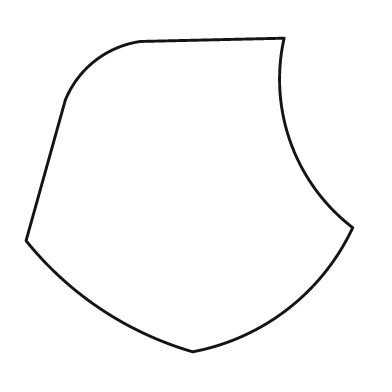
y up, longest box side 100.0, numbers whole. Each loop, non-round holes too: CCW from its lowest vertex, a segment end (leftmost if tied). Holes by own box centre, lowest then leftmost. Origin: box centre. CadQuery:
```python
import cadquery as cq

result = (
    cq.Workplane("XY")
    .moveTo(1.0, -48.0)
    .threePointArc((30.0, -35.0), (50.0, -10.0))
    .threePointArc((31.0, 16.0), (29.0, 48.0))
    .lineTo(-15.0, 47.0)
    .threePointArc((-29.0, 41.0), (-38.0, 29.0))
    .lineTo(-50.0, -14.0)
    .threePointArc((-27.0, -35.0), (1.0, -48.0))
    .close()
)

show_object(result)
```